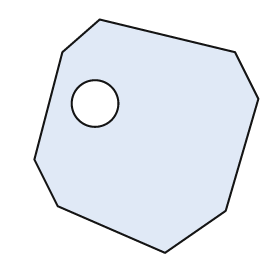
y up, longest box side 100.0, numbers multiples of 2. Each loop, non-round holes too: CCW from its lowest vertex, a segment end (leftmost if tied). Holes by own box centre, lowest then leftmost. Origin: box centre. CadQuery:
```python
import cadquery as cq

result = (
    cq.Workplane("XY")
    .moveTo(8.0, -50.0)
    .lineTo(34.0, -32.0)
    .lineTo(48.0, 16.0)
    .lineTo(38.0, 36.0)
    .lineTo(-20.0, 50.0)
    .lineTo(-36.0, 36.0)
    .lineTo(-48.0, -10.0)
    .lineTo(-38.0, -30.0)
    .close()
    .moveTo(-22.0, 14.0)
    .circle(10.0)
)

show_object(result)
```